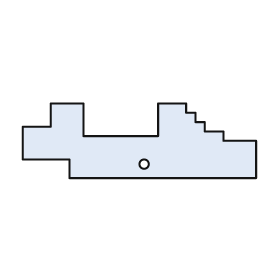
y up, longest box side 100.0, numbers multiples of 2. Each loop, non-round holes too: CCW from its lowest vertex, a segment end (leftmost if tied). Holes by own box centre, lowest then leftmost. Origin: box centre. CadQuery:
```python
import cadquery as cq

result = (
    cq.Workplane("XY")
    .moveTo(-30.0, -16.0)
    .lineTo(50.0, -16.0)
    .lineTo(50.0, 0.0)
    .lineTo(36.0, 0.0)
    .lineTo(36.0, 4.0)
    .lineTo(28.0, 4.0)
    .lineTo(28.0, 8.0)
    .lineTo(24.0, 8.0)
    .lineTo(24.0, 12.0)
    .lineTo(20.0, 12.0)
    .lineTo(20.0, 16.0)
    .lineTo(8.0, 16.0)
    .lineTo(8.0, 2.0)
    .lineTo(-24.0, 2.0)
    .lineTo(-24.0, 16.0)
    .lineTo(-38.0, 16.0)
    .lineTo(-38.0, 6.0)
    .lineTo(-50.0, 6.0)
    .lineTo(-50.0, -8.0)
    .lineTo(-30.0, -8.0)
    .close()
    .moveTo(2.0, -10.0)
    .circle(2.0)
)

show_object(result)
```